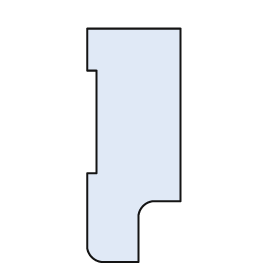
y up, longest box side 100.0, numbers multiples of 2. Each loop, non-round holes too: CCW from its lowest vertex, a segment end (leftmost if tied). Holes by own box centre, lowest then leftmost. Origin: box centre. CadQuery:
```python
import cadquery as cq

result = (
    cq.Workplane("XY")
    .moveTo(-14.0, -50.0)
    .lineTo(2.0, -50.0)
    .lineTo(2.0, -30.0)
    .threePointArc((4.0, -26.0), (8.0, -24.0))
    .lineTo(20.0, -24.0)
    .lineTo(20.0, 50.0)
    .lineTo(-20.0, 50.0)
    .lineTo(-20.0, 32.0)
    .lineTo(-16.0, 32.0)
    .lineTo(-16.0, -12.0)
    .lineTo(-20.0, -12.0)
    .lineTo(-20.0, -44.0)
    .threePointArc((-18.0, -48.0), (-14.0, -50.0))
    .close()
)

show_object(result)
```